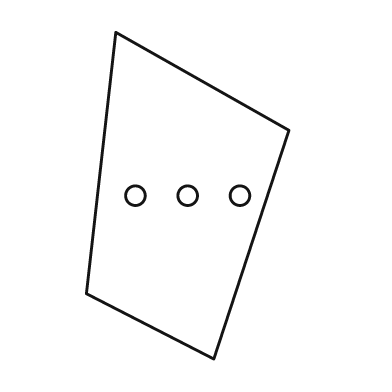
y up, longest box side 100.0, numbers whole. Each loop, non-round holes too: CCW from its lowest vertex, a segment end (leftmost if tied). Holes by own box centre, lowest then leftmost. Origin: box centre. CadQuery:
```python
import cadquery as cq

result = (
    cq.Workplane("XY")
    .moveTo(8.0, -50.0)
    .lineTo(31.0, 20.0)
    .lineTo(-22.0, 50.0)
    .lineTo(-31.0, -30.0)
    .close()
    .moveTo(-16.0, 0.0)
    .circle(3.0)
    .moveTo(0.0, 0.0)
    .circle(3.0)
    .moveTo(16.0, 0.0)
    .circle(3.0)
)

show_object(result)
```